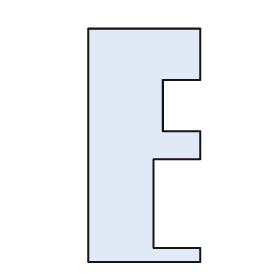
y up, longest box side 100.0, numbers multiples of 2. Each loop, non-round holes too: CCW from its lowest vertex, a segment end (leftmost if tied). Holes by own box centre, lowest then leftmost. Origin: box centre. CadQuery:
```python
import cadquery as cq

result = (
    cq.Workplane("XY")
    .moveTo(-24.0, -50.0)
    .lineTo(24.0, -50.0)
    .lineTo(24.0, -44.0)
    .lineTo(4.0, -44.0)
    .lineTo(4.0, -6.0)
    .lineTo(24.0, -6.0)
    .lineTo(24.0, 6.0)
    .lineTo(8.0, 6.0)
    .lineTo(8.0, 28.0)
    .lineTo(24.0, 28.0)
    .lineTo(24.0, 50.0)
    .lineTo(-24.0, 50.0)
    .close()
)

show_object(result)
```